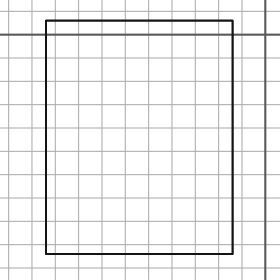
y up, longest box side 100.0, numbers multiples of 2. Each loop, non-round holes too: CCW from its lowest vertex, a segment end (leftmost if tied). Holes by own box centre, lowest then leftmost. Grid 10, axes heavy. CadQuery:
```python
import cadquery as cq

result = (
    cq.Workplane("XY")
    .moveTo(-94.0, -94.0)
    .lineTo(-14.0, -94.0)
    .lineTo(-14.0, 6.0)
    .lineTo(-94.0, 6.0)
    .close()
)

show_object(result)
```